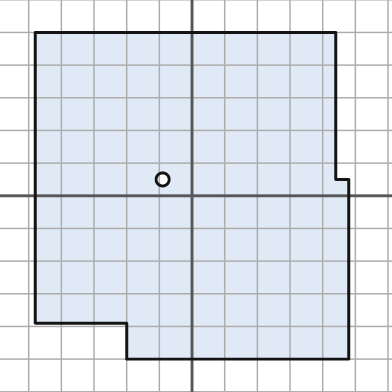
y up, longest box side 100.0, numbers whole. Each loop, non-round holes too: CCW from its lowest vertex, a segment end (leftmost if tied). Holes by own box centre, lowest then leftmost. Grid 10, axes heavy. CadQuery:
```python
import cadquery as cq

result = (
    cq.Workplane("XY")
    .moveTo(-20.0, -50.0)
    .lineTo(48.0, -50.0)
    .lineTo(48.0, 5.0)
    .lineTo(44.0, 5.0)
    .lineTo(44.0, 50.0)
    .lineTo(-48.0, 50.0)
    .lineTo(-48.0, -39.0)
    .lineTo(-20.0, -39.0)
    .close()
    .moveTo(-9.0, 5.0)
    .circle(2.0)
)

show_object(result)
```